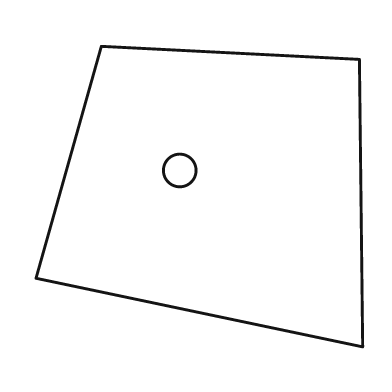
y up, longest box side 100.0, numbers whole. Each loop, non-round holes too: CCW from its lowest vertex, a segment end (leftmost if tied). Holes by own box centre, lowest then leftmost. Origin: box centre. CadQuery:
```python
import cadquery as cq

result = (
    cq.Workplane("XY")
    .moveTo(50.0, -46.0)
    .lineTo(49.0, 42.0)
    .lineTo(-30.0, 46.0)
    .lineTo(-50.0, -25.0)
    .close()
    .moveTo(-6.0, 8.0)
    .circle(5.0)
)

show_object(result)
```